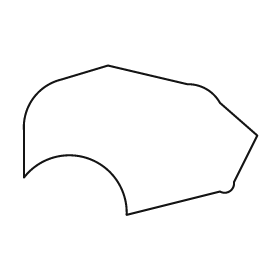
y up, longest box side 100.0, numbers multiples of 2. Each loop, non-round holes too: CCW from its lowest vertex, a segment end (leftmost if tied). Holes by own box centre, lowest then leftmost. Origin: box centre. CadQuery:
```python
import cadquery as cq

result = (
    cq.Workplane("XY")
    .moveTo(-6.0, -32.0)
    .lineTo(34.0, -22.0)
    .threePointArc((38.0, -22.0), (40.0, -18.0))
    .lineTo(50.0, 2.0)
    .lineTo(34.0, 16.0)
    .threePointArc((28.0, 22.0), (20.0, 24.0))
    .lineTo(-14.0, 32.0)
    .lineTo(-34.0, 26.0)
    .threePointArc((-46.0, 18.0), (-50.0, 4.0))
    .lineTo(-50.0, -16.0)
    .threePointArc((-22.0, -8.0), (-6.0, -32.0))
    .close()
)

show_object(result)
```